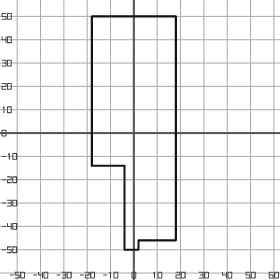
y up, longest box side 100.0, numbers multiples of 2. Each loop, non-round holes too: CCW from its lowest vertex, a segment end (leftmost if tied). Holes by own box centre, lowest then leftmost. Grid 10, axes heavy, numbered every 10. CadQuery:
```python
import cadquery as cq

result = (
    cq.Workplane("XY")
    .moveTo(-4.0, -50.0)
    .lineTo(2.0, -50.0)
    .lineTo(2.0, -46.0)
    .lineTo(18.0, -46.0)
    .lineTo(18.0, 50.0)
    .lineTo(-18.0, 50.0)
    .lineTo(-18.0, -14.0)
    .lineTo(-4.0, -14.0)
    .close()
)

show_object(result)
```